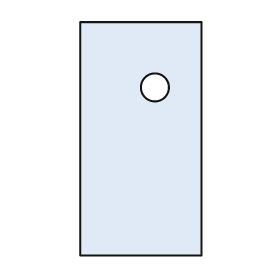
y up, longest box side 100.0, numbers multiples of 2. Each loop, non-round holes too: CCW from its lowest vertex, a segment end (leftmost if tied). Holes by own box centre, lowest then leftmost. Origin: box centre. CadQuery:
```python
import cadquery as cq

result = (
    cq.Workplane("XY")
    .moveTo(-26.0, -50.0)
    .lineTo(26.0, -50.0)
    .lineTo(26.0, 50.0)
    .lineTo(-26.0, 50.0)
    .close()
    .moveTo(6.0, 22.0)
    .circle(6.0)
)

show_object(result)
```